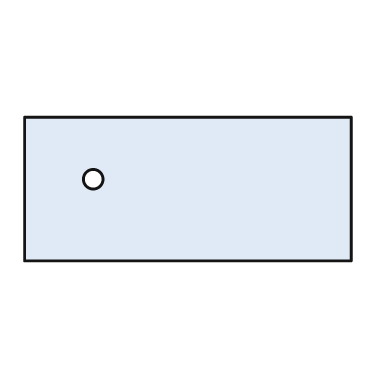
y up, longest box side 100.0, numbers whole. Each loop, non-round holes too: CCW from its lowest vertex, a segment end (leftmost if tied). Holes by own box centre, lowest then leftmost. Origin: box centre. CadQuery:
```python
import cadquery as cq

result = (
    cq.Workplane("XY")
    .moveTo(-50.0, -22.0)
    .lineTo(50.0, -22.0)
    .lineTo(50.0, 22.0)
    .lineTo(-50.0, 22.0)
    .close()
    .moveTo(-29.0, 3.0)
    .circle(3.0)
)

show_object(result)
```